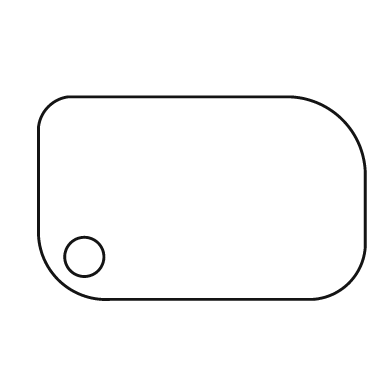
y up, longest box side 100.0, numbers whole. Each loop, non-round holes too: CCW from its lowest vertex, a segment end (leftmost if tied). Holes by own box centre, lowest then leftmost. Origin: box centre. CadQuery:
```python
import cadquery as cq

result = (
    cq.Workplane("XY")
    .moveTo(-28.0, -31.0)
    .lineTo(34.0, -31.0)
    .threePointArc((45.0, -26.0), (50.0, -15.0))
    .lineTo(50.0, 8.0)
    .threePointArc((43.0, 24.0), (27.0, 31.0))
    .lineTo(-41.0, 31.0)
    .threePointArc((-47.0, 28.0), (-50.0, 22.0))
    .lineTo(-50.0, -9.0)
    .threePointArc((-44.0, -25.0), (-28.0, -31.0))
    .close()
    .moveTo(-36.0, -18.0)
    .circle(6.0)
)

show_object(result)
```